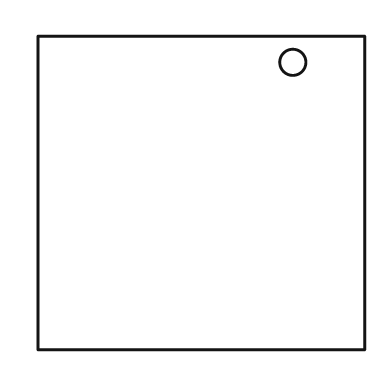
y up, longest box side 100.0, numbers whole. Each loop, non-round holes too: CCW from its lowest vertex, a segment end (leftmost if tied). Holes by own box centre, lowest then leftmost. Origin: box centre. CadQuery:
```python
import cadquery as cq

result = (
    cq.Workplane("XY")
    .moveTo(-50.0, -48.0)
    .lineTo(50.0, -48.0)
    .lineTo(50.0, 48.0)
    .lineTo(-50.0, 48.0)
    .close()
    .moveTo(28.0, 40.0)
    .circle(4.0)
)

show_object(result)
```